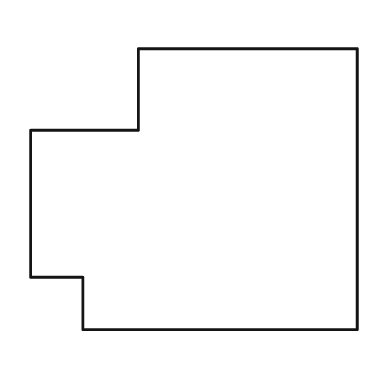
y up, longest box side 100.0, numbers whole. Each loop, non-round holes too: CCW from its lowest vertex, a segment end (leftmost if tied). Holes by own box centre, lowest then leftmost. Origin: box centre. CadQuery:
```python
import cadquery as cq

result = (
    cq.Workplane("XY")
    .moveTo(-34.0, -43.0)
    .lineTo(50.0, -43.0)
    .lineTo(50.0, 43.0)
    .lineTo(-17.0, 43.0)
    .lineTo(-17.0, 18.0)
    .lineTo(-50.0, 18.0)
    .lineTo(-50.0, -27.0)
    .lineTo(-34.0, -27.0)
    .close()
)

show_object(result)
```